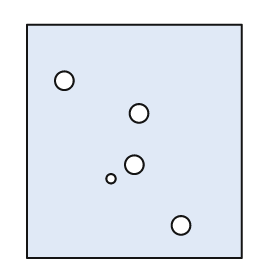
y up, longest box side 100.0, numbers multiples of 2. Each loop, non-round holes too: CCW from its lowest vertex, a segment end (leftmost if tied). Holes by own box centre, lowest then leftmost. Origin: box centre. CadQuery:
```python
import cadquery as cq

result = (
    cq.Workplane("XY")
    .moveTo(-46.0, -50.0)
    .lineTo(46.0, -50.0)
    .lineTo(46.0, 50.0)
    .lineTo(-46.0, 50.0)
    .close()
    .moveTo(20.0, -36.0)
    .circle(4.0)
    .moveTo(-10.0, -16.0)
    .circle(2.0)
    .moveTo(0.0, -10.0)
    .circle(4.0)
    .moveTo(2.0, 12.0)
    .circle(4.0)
    .moveTo(-30.0, 26.0)
    .circle(4.0)
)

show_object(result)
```